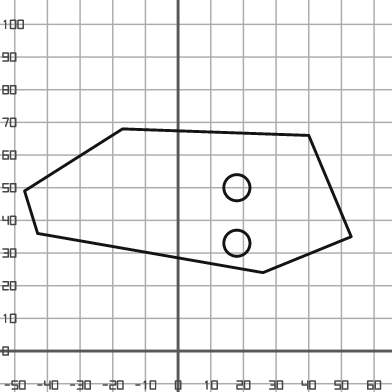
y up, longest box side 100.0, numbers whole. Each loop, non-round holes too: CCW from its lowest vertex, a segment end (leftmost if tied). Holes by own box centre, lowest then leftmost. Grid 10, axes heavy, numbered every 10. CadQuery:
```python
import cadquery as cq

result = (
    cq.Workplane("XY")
    .moveTo(26.0, 24.0)
    .lineTo(53.0, 35.0)
    .lineTo(40.0, 66.0)
    .lineTo(-17.0, 68.0)
    .lineTo(-47.0, 49.0)
    .lineTo(-43.0, 36.0)
    .close()
    .moveTo(18.0, 33.0)
    .circle(4.0)
    .moveTo(18.0, 50.0)
    .circle(4.0)
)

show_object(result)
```